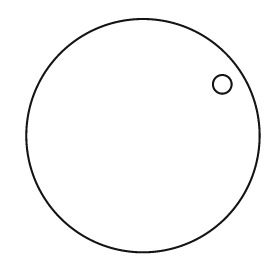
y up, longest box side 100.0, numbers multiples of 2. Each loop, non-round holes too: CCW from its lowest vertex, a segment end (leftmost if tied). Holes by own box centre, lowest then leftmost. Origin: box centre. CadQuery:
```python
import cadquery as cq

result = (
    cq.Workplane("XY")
    .moveTo(0.0, 0.0)
    .circle(50.0)
    .moveTo(34.0, 22.0)
    .circle(4.0)
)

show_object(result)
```